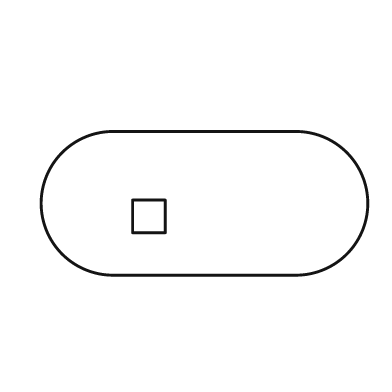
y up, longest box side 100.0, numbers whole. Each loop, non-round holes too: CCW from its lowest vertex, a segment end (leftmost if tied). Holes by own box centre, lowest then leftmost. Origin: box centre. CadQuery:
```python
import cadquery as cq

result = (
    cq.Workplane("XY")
    .moveTo(-28.0, -22.0)
    .lineTo(28.0, -22.0)
    .threePointArc((50.0, 0.0), (28.0, 22.0))
    .lineTo(-28.0, 22.0)
    .threePointArc((-50.0, 0.0), (-28.0, -22.0))
    .close()
    .moveTo(-22.0, -9.0)
    .lineTo(-12.0, -9.0)
    .lineTo(-12.0, 1.0)
    .lineTo(-22.0, 1.0)
    .close()
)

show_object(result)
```